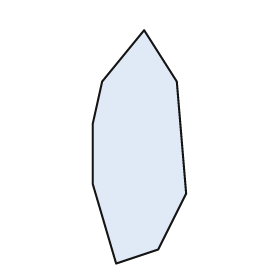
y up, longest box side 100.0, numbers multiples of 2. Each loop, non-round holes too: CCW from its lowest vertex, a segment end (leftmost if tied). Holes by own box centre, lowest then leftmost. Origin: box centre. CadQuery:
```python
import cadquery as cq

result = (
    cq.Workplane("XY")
    .moveTo(-10.0, -50.0)
    .lineTo(8.0, -44.0)
    .lineTo(20.0, -20.0)
    .lineTo(16.0, 28.0)
    .lineTo(2.0, 50.0)
    .lineTo(-16.0, 28.0)
    .lineTo(-20.0, 10.0)
    .lineTo(-20.0, -16.0)
    .close()
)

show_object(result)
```